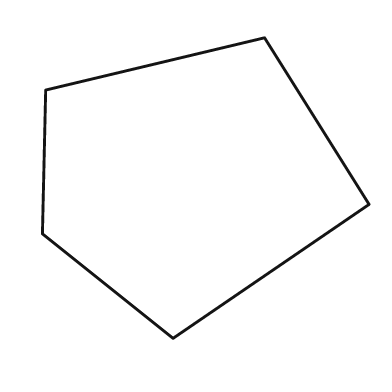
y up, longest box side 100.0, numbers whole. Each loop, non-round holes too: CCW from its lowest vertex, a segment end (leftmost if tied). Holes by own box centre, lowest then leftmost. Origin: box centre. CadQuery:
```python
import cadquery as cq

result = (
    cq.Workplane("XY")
    .moveTo(-10.0, -46.0)
    .lineTo(50.0, -5.0)
    .lineTo(18.0, 46.0)
    .lineTo(-49.0, 30.0)
    .lineTo(-50.0, -14.0)
    .close()
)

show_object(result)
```